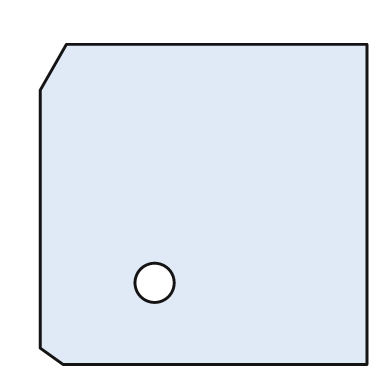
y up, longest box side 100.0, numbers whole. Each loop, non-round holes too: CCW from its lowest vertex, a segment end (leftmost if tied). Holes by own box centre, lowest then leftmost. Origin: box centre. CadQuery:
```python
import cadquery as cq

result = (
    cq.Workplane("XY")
    .moveTo(-43.0, -49.0)
    .lineTo(50.0, -49.0)
    .lineTo(50.0, 49.0)
    .lineTo(-42.0, 49.0)
    .lineTo(-50.0, 35.0)
    .lineTo(-50.0, -44.0)
    .close()
    .moveTo(-15.0, -24.0)
    .circle(6.0)
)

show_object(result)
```